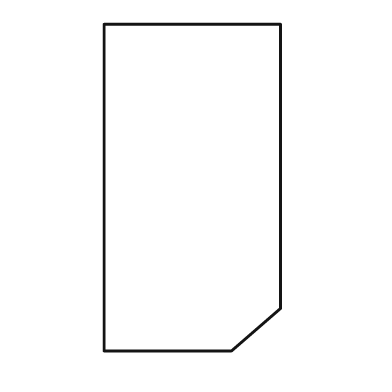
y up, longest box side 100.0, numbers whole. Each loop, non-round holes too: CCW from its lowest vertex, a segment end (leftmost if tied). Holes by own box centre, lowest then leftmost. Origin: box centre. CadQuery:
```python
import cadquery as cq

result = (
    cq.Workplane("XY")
    .moveTo(-27.0, -50.0)
    .lineTo(12.0, -50.0)
    .lineTo(27.0, -37.0)
    .lineTo(27.0, 50.0)
    .lineTo(-27.0, 50.0)
    .close()
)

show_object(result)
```